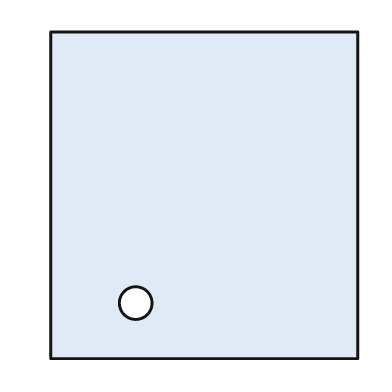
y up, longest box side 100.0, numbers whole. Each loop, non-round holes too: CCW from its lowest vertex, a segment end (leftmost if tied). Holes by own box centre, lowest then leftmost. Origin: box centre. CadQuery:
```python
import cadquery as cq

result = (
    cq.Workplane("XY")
    .moveTo(-47.0, -50.0)
    .lineTo(47.0, -50.0)
    .lineTo(47.0, 50.0)
    .lineTo(-47.0, 50.0)
    .close()
    .moveTo(-21.0, -33.0)
    .circle(5.0)
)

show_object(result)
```